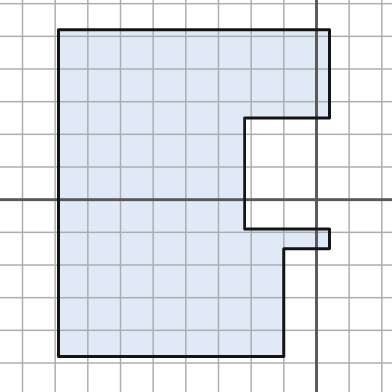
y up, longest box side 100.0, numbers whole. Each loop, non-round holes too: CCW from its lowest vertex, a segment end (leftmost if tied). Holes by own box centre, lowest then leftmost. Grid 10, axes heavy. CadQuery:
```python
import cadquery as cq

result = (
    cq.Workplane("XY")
    .moveTo(-79.0, -48.0)
    .lineTo(-10.0, -48.0)
    .lineTo(-10.0, -15.0)
    .lineTo(4.0, -15.0)
    .lineTo(4.0, -9.0)
    .lineTo(-22.0, -9.0)
    .lineTo(-22.0, 25.0)
    .lineTo(4.0, 25.0)
    .lineTo(4.0, 52.0)
    .lineTo(-79.0, 52.0)
    .close()
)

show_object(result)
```